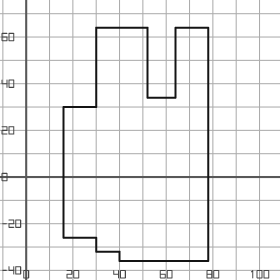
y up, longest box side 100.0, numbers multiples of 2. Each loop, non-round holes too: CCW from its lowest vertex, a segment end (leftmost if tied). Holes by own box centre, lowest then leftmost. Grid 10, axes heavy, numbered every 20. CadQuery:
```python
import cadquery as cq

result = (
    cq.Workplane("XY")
    .moveTo(40.0, -36.0)
    .lineTo(78.0, -36.0)
    .lineTo(78.0, 64.0)
    .lineTo(64.0, 64.0)
    .lineTo(64.0, 34.0)
    .lineTo(52.0, 34.0)
    .lineTo(52.0, 64.0)
    .lineTo(30.0, 64.0)
    .lineTo(30.0, 30.0)
    .lineTo(16.0, 30.0)
    .lineTo(16.0, -26.0)
    .lineTo(30.0, -26.0)
    .lineTo(30.0, -32.0)
    .lineTo(40.0, -32.0)
    .close()
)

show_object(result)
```